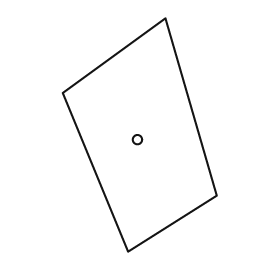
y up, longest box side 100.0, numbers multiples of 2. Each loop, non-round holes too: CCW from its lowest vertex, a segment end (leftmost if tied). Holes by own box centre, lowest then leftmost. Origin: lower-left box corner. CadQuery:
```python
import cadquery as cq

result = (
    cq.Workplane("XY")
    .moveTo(28.0, 0.0)
    .lineTo(66.0, 24.0)
    .lineTo(44.0, 100.0)
    .lineTo(0.0, 68.0)
    .close()
    .moveTo(32.0, 48.0)
    .circle(2.0)
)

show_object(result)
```